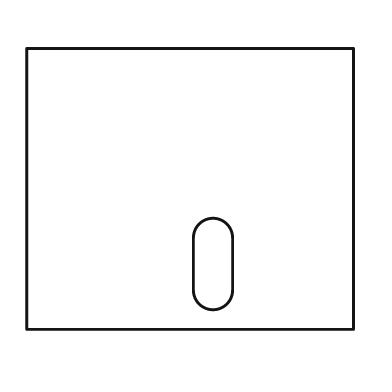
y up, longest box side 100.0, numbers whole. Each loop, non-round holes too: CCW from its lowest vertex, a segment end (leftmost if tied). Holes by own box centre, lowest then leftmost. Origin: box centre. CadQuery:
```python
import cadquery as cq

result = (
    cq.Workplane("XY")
    .moveTo(-50.0, -43.0)
    .lineTo(50.0, -43.0)
    .lineTo(50.0, 43.0)
    .lineTo(-50.0, 43.0)
    .close()
    .moveTo(1.0, -31.0)
    .threePointArc((7.0, -37.0), (13.0, -31.0))
    .lineTo(13.0, -15.0)
    .threePointArc((7.0, -9.0), (1.0, -15.0))
    .close()
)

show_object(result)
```